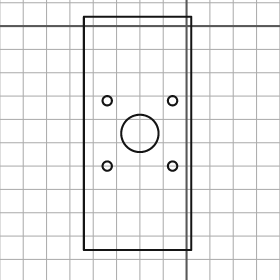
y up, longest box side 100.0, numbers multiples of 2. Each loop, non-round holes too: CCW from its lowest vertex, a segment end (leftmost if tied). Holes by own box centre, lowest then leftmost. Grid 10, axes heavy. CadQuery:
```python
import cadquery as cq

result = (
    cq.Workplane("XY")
    .moveTo(-44.0, -96.0)
    .lineTo(2.0, -96.0)
    .lineTo(2.0, 4.0)
    .lineTo(-44.0, 4.0)
    .close()
    .moveTo(-34.0, -60.0)
    .circle(2.0)
    .moveTo(-6.0, -60.0)
    .circle(2.0)
    .moveTo(-20.0, -46.0)
    .circle(8.0)
    .moveTo(-34.0, -32.0)
    .circle(2.0)
    .moveTo(-6.0, -32.0)
    .circle(2.0)
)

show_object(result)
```